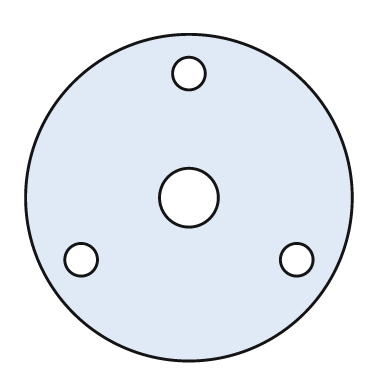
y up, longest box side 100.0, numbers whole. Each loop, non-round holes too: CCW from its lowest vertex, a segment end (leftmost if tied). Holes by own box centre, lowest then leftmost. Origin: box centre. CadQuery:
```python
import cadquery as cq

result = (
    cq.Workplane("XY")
    .moveTo(0.0, 0.0)
    .circle(50.0)
    .moveTo(-33.0, -19.0)
    .circle(5.0)
    .moveTo(33.0, -19.0)
    .circle(5.0)
    .moveTo(0.0, 0.0)
    .circle(9.0)
    .moveTo(0.0, 38.0)
    .circle(5.0)
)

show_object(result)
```